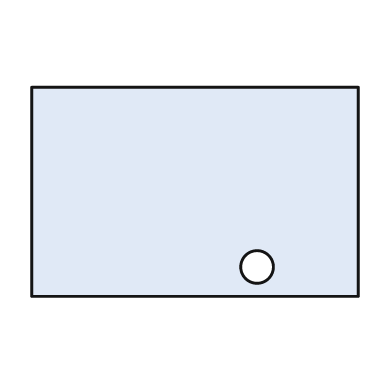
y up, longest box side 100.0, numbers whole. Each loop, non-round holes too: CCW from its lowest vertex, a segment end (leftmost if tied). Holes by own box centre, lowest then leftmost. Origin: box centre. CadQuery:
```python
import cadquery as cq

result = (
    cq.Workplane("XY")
    .moveTo(-50.0, -32.0)
    .lineTo(50.0, -32.0)
    .lineTo(50.0, 32.0)
    .lineTo(-50.0, 32.0)
    .close()
    .moveTo(19.0, -23.0)
    .circle(5.0)
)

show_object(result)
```